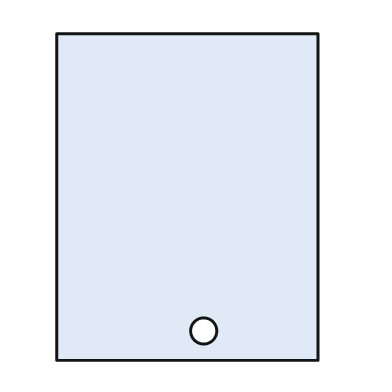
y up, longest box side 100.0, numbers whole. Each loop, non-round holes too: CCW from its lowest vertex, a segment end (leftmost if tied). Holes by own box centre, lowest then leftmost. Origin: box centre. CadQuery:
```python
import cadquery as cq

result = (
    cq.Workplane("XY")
    .moveTo(-40.0, -50.0)
    .lineTo(40.0, -50.0)
    .lineTo(40.0, 50.0)
    .lineTo(-40.0, 50.0)
    .close()
    .moveTo(5.0, -41.0)
    .circle(4.0)
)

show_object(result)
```